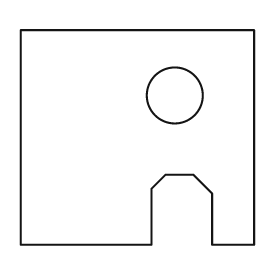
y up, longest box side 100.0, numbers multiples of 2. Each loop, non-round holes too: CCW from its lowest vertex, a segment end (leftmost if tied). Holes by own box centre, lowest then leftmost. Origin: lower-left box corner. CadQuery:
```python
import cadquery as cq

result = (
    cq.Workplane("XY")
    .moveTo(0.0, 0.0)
    .lineTo(56.0, 0.0)
    .lineTo(56.0, 24.0)
    .lineTo(62.0, 30.0)
    .lineTo(74.0, 30.0)
    .lineTo(82.0, 22.0)
    .lineTo(82.0, 0.0)
    .lineTo(100.0, 0.0)
    .lineTo(100.0, 92.0)
    .lineTo(0.0, 92.0)
    .close()
    .moveTo(66.0, 64.0)
    .circle(12.0)
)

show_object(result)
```